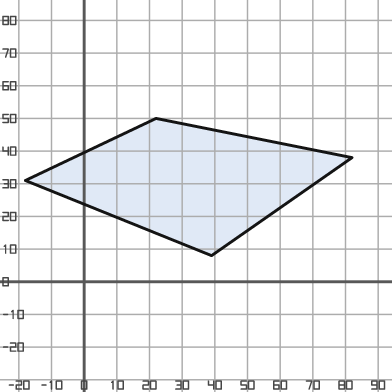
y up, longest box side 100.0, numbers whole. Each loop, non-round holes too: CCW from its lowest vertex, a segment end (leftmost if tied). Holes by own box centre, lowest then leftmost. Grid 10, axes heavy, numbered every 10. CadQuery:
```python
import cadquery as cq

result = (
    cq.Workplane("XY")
    .moveTo(39.0, 8.0)
    .lineTo(82.0, 38.0)
    .lineTo(22.0, 50.0)
    .lineTo(-18.0, 31.0)
    .close()
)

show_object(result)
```